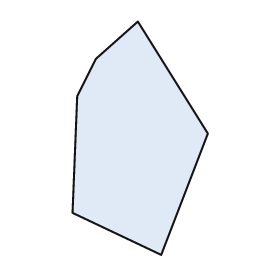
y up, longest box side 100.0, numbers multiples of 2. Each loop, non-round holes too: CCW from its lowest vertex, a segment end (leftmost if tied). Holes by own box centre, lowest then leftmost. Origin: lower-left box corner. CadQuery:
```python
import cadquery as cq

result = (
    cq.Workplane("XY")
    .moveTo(38.0, 0.0)
    .lineTo(58.0, 52.0)
    .lineTo(28.0, 100.0)
    .lineTo(10.0, 84.0)
    .lineTo(2.0, 68.0)
    .lineTo(0.0, 18.0)
    .close()
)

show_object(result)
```